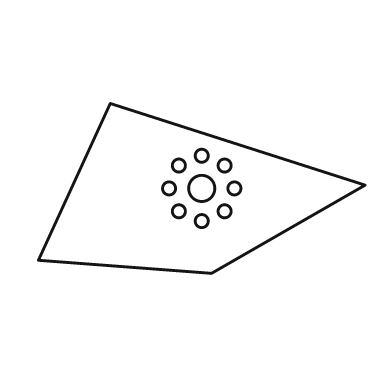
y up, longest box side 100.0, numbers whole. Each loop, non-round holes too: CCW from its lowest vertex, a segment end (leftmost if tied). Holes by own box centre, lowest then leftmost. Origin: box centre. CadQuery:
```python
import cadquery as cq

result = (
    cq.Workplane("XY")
    .moveTo(3.0, -26.0)
    .lineTo(50.0, 1.0)
    .lineTo(-28.0, 26.0)
    .lineTo(-50.0, -22.0)
    .close()
    .moveTo(0.0, -10.0)
    .circle(2.0)
    .moveTo(-7.0, -7.0)
    .circle(2.0)
    .moveTo(7.0, -7.0)
    .circle(2.0)
    .moveTo(-10.0, 0.0)
    .circle(2.0)
    .moveTo(0.0, 0.0)
    .circle(4.0)
    .moveTo(10.0, 0.0)
    .circle(2.0)
    .moveTo(-7.0, 7.0)
    .circle(2.0)
    .moveTo(7.0, 7.0)
    .circle(2.0)
    .moveTo(0.0, 10.0)
    .circle(2.0)
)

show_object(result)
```